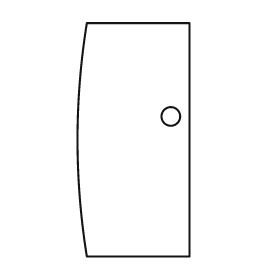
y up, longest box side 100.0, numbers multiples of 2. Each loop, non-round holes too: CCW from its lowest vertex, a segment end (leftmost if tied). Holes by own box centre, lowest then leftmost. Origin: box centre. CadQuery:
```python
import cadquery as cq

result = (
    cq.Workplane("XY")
    .moveTo(-20.0, -50.0)
    .lineTo(24.0, -50.0)
    .lineTo(24.0, 50.0)
    .lineTo(-20.0, 50.0)
    .threePointArc((-24.0, 0.0), (-20.0, -50.0))
    .close()
    .moveTo(16.0, 10.0)
    .circle(4.0)
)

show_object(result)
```